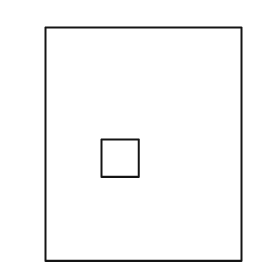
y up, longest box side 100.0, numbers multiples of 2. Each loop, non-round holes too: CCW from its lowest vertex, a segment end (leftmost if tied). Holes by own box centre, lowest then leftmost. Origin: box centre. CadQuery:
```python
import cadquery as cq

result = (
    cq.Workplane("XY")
    .moveTo(-42.0, -50.0)
    .lineTo(42.0, -50.0)
    .lineTo(42.0, 50.0)
    .lineTo(-42.0, 50.0)
    .close()
    .moveTo(-18.0, -14.0)
    .lineTo(-2.0, -14.0)
    .lineTo(-2.0, 2.0)
    .lineTo(-18.0, 2.0)
    .close()
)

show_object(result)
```